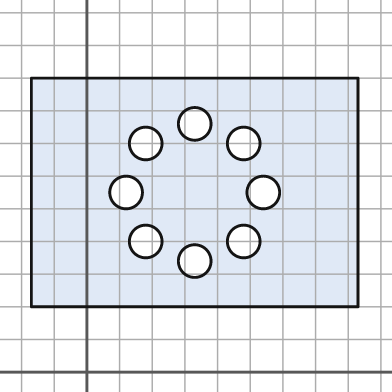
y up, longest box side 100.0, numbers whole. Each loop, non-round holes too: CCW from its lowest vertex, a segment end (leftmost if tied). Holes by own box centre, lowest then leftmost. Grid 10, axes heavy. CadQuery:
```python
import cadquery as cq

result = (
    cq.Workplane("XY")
    .moveTo(-17.0, 20.0)
    .lineTo(83.0, 20.0)
    .lineTo(83.0, 90.0)
    .lineTo(-17.0, 90.0)
    .close()
    .moveTo(33.0, 34.0)
    .circle(5.0)
    .moveTo(18.0, 40.0)
    .circle(5.0)
    .moveTo(48.0, 40.0)
    .circle(5.0)
    .moveTo(12.0, 55.0)
    .circle(5.0)
    .moveTo(54.0, 55.0)
    .circle(5.0)
    .moveTo(18.0, 70.0)
    .circle(5.0)
    .moveTo(48.0, 70.0)
    .circle(5.0)
    .moveTo(33.0, 76.0)
    .circle(5.0)
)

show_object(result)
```